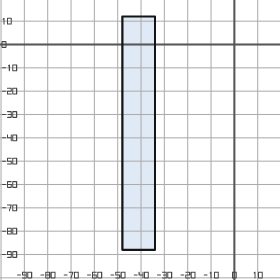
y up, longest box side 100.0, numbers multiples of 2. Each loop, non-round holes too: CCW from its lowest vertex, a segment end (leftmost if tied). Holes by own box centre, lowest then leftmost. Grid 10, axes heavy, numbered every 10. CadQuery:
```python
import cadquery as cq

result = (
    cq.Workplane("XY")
    .moveTo(-48.0, -88.0)
    .lineTo(-34.0, -88.0)
    .lineTo(-34.0, 12.0)
    .lineTo(-48.0, 12.0)
    .close()
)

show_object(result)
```